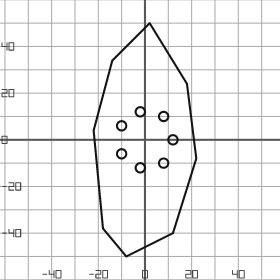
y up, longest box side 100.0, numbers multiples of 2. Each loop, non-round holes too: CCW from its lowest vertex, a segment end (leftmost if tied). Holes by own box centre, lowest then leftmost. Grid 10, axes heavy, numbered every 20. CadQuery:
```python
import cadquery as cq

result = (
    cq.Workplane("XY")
    .moveTo(-8.0, -50.0)
    .lineTo(12.0, -40.0)
    .lineTo(22.0, -8.0)
    .lineTo(18.0, 24.0)
    .lineTo(2.0, 50.0)
    .lineTo(-14.0, 34.0)
    .lineTo(-22.0, 4.0)
    .lineTo(-18.0, -38.0)
    .close()
    .moveTo(-2.0, -12.0)
    .circle(2.0)
    .moveTo(8.0, -10.0)
    .circle(2.0)
    .moveTo(-10.0, -6.0)
    .circle(2.0)
    .moveTo(12.0, 0.0)
    .circle(2.0)
    .moveTo(-10.0, 6.0)
    .circle(2.0)
    .moveTo(8.0, 10.0)
    .circle(2.0)
    .moveTo(-2.0, 12.0)
    .circle(2.0)
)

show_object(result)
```